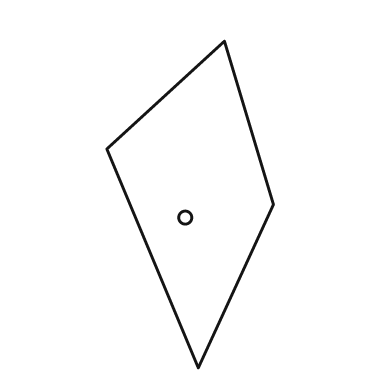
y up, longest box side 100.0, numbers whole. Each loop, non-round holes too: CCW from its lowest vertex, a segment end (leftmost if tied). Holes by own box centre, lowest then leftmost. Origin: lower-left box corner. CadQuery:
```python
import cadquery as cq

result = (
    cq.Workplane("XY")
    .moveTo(28.0, 0.0)
    .lineTo(51.0, 50.0)
    .lineTo(36.0, 100.0)
    .lineTo(0.0, 67.0)
    .close()
    .moveTo(24.0, 46.0)
    .circle(2.0)
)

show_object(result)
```